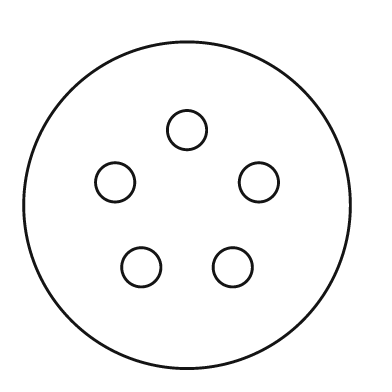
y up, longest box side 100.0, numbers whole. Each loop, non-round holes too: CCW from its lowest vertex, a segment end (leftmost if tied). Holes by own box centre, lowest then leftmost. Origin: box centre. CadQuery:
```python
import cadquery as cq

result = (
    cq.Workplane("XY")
    .moveTo(0.0, 0.0)
    .circle(50.0)
    .moveTo(-14.0, -19.0)
    .circle(6.0)
    .moveTo(14.0, -19.0)
    .circle(6.0)
    .moveTo(-22.0, 7.0)
    .circle(6.0)
    .moveTo(22.0, 7.0)
    .circle(6.0)
    .moveTo(0.0, 23.0)
    .circle(6.0)
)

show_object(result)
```